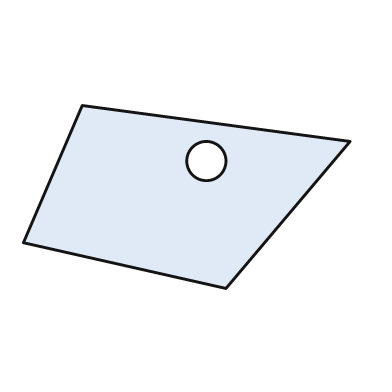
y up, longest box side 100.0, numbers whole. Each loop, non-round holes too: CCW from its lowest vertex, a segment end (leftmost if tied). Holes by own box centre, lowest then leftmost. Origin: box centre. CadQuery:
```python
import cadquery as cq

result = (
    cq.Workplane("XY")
    .moveTo(12.0, -28.0)
    .lineTo(50.0, 17.0)
    .lineTo(-32.0, 28.0)
    .lineTo(-50.0, -14.0)
    .close()
    .moveTo(6.0, 11.0)
    .circle(6.0)
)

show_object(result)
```